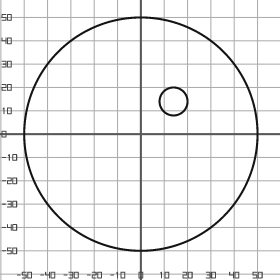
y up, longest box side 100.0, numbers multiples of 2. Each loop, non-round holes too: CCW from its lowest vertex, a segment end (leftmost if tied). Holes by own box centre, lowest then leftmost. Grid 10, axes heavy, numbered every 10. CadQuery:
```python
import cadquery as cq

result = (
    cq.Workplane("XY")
    .moveTo(0.0, 0.0)
    .circle(50.0)
    .moveTo(14.0, 14.0)
    .circle(6.0)
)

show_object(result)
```